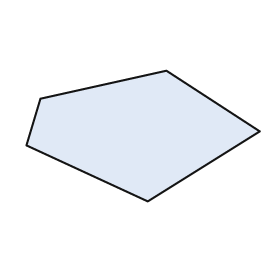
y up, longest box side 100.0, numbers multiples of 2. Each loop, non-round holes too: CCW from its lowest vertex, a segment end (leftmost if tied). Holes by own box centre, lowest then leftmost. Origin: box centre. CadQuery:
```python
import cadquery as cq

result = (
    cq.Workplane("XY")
    .moveTo(2.0, -28.0)
    .lineTo(50.0, 2.0)
    .lineTo(10.0, 28.0)
    .lineTo(-44.0, 16.0)
    .lineTo(-50.0, -4.0)
    .close()
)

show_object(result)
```